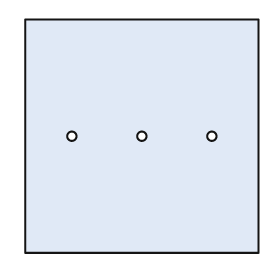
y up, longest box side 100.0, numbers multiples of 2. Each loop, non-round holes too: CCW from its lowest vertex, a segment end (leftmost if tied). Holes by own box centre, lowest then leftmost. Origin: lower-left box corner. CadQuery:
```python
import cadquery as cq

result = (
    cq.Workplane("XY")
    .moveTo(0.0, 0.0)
    .lineTo(100.0, 0.0)
    .lineTo(100.0, 100.0)
    .lineTo(0.0, 100.0)
    .close()
    .moveTo(20.0, 50.0)
    .circle(2.0)
    .moveTo(50.0, 50.0)
    .circle(2.0)
    .moveTo(80.0, 50.0)
    .circle(2.0)
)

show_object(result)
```